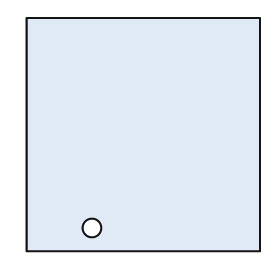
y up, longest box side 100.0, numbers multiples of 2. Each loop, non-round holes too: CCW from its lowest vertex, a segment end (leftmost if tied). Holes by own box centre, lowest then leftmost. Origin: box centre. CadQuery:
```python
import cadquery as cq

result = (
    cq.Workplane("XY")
    .moveTo(-50.0, -50.0)
    .lineTo(50.0, -50.0)
    .lineTo(50.0, 50.0)
    .lineTo(-50.0, 50.0)
    .close()
    .moveTo(-22.0, -40.0)
    .circle(4.0)
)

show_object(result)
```